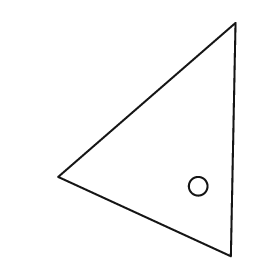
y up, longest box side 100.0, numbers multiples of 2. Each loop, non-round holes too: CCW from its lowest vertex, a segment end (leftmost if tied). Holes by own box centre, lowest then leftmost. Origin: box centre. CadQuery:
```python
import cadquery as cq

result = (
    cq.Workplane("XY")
    .moveTo(36.0, -50.0)
    .lineTo(38.0, 50.0)
    .lineTo(-38.0, -16.0)
    .close()
    .moveTo(22.0, -20.0)
    .circle(4.0)
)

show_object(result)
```